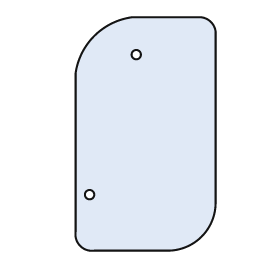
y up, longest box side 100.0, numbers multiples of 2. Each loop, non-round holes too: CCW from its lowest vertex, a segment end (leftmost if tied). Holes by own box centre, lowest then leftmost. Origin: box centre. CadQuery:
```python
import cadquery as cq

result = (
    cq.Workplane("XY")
    .moveTo(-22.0, -50.0)
    .lineTo(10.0, -50.0)
    .threePointArc((24.0, -44.0), (30.0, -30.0))
    .lineTo(30.0, 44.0)
    .threePointArc((28.0, 48.0), (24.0, 50.0))
    .lineTo(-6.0, 50.0)
    .threePointArc((-22.0, 42.0), (-30.0, 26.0))
    .lineTo(-30.0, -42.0)
    .threePointArc((-28.0, -48.0), (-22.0, -50.0))
    .close()
    .moveTo(-24.0, -26.0)
    .circle(2.0)
    .moveTo(-4.0, 34.0)
    .circle(2.0)
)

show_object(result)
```